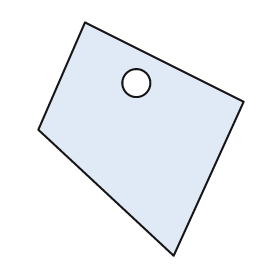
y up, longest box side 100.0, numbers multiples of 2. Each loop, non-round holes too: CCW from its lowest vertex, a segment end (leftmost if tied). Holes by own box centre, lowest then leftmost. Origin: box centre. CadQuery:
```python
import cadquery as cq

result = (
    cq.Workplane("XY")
    .moveTo(14.0, -50.0)
    .lineTo(44.0, 16.0)
    .lineTo(-24.0, 50.0)
    .lineTo(-44.0, 4.0)
    .close()
    .moveTo(-2.0, 24.0)
    .circle(6.0)
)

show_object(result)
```